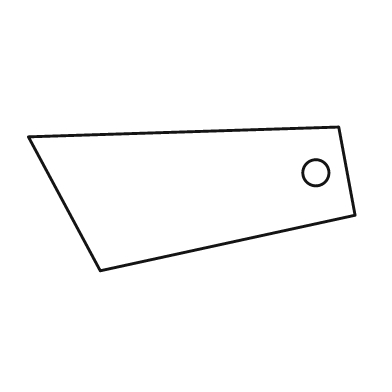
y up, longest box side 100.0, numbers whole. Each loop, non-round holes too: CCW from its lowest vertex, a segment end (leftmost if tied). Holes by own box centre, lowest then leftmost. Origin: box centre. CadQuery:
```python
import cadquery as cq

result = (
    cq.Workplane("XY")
    .moveTo(-28.0, -22.0)
    .lineTo(50.0, -5.0)
    .lineTo(45.0, 22.0)
    .lineTo(-50.0, 19.0)
    .close()
    .moveTo(38.0, 8.0)
    .circle(4.0)
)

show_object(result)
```